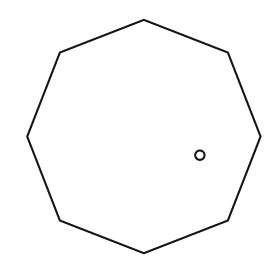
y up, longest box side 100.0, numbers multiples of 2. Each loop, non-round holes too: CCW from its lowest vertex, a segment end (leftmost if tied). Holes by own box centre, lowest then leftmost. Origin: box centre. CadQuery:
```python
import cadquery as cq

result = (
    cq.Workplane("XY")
    .moveTo(0.0, -50.0)
    .lineTo(36.0, -36.0)
    .lineTo(50.0, 0.0)
    .lineTo(36.0, 36.0)
    .lineTo(0.0, 50.0)
    .lineTo(-36.0, 36.0)
    .lineTo(-50.0, 0.0)
    .lineTo(-36.0, -36.0)
    .close()
    .moveTo(24.0, -8.0)
    .circle(2.0)
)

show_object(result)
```